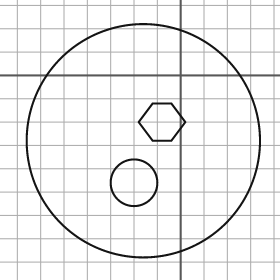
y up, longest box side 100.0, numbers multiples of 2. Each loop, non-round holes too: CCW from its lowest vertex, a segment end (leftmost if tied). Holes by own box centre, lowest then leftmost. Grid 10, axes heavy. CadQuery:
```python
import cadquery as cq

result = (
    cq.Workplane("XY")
    .moveTo(-16.0, -28.0)
    .circle(50.0)
    .moveTo(-20.0, -46.0)
    .circle(10.0)
    .moveTo(-12.0, -28.0)
    .lineTo(-4.0, -28.0)
    .lineTo(2.0, -20.0)
    .lineTo(-4.0, -12.0)
    .lineTo(-12.0, -12.0)
    .lineTo(-18.0, -20.0)
    .close()
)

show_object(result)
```